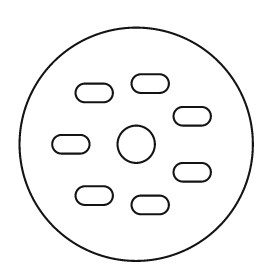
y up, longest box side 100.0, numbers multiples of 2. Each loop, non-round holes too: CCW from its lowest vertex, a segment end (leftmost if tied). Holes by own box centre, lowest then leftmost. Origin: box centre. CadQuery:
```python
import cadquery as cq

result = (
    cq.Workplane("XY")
    .moveTo(0.0, 0.0)
    .circle(50.0)
    .moveTo(2.0, -30.0)
    .lineTo(10.0, -30.0)
    .threePointArc((14.0, -26.0), (10.0, -22.0))
    .lineTo(2.0, -22.0)
    .threePointArc((-2.0, -26.0), (2.0, -30.0))
    .close()
    .moveTo(-22.0, -26.0)
    .lineTo(-14.0, -26.0)
    .threePointArc((-10.0, -22.0), (-14.0, -18.0))
    .lineTo(-22.0, -18.0)
    .threePointArc((-26.0, -22.0), (-22.0, -26.0))
    .close()
    .moveTo(20.0, -16.0)
    .lineTo(28.0, -16.0)
    .threePointArc((32.0, -12.0), (28.0, -8.0))
    .lineTo(20.0, -8.0)
    .threePointArc((16.0, -12.0), (20.0, -16.0))
    .close()
    .moveTo(-32.0, -4.0)
    .lineTo(-24.0, -4.0)
    .threePointArc((-20.0, 0.0), (-24.0, 4.0))
    .lineTo(-32.0, 4.0)
    .threePointArc((-36.0, 0.0), (-32.0, -4.0))
    .close()
    .moveTo(0.0, 0.0)
    .circle(8.0)
    .moveTo(20.0, 8.0)
    .lineTo(28.0, 8.0)
    .threePointArc((32.0, 12.0), (28.0, 16.0))
    .lineTo(20.0, 16.0)
    .threePointArc((16.0, 12.0), (20.0, 8.0))
    .close()
    .moveTo(-22.0, 18.0)
    .lineTo(-14.0, 18.0)
    .threePointArc((-10.0, 22.0), (-14.0, 26.0))
    .lineTo(-22.0, 26.0)
    .threePointArc((-26.0, 22.0), (-22.0, 18.0))
    .close()
    .moveTo(2.0, 22.0)
    .lineTo(10.0, 22.0)
    .threePointArc((14.0, 26.0), (10.0, 30.0))
    .lineTo(2.0, 30.0)
    .threePointArc((-2.0, 26.0), (2.0, 22.0))
    .close()
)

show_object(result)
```